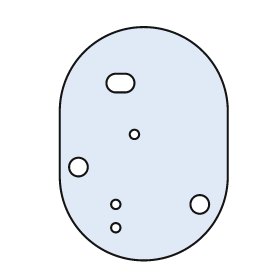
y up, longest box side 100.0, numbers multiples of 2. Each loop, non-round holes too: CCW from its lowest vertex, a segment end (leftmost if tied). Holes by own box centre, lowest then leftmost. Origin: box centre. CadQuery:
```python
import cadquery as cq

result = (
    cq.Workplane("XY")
    .moveTo(-36.0, -14.0)
    .threePointArc((0.0, -50.0), (36.0, -14.0))
    .lineTo(36.0, 14.0)
    .threePointArc((0.0, 50.0), (-36.0, 14.0))
    .close()
    .moveTo(-12.0, -36.0)
    .circle(2.0)
    .moveTo(-12.0, -26.0)
    .circle(2.0)
    .moveTo(24.0, -26.0)
    .circle(4.0)
    .moveTo(-28.0, -10.0)
    .circle(4.0)
    .moveTo(-4.0, 4.0)
    .circle(2.0)
    .moveTo(-12.0, 22.0)
    .lineTo(-8.0, 22.0)
    .threePointArc((-4.0, 26.0), (-8.0, 30.0))
    .lineTo(-12.0, 30.0)
    .threePointArc((-16.0, 26.0), (-12.0, 22.0))
    .close()
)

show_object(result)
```